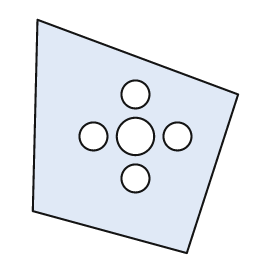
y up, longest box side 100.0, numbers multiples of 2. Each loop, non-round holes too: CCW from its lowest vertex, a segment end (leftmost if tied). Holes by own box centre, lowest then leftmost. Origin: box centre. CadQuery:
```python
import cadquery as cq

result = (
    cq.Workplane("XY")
    .moveTo(22.0, -50.0)
    .lineTo(44.0, 18.0)
    .lineTo(-42.0, 50.0)
    .lineTo(-44.0, -32.0)
    .close()
    .moveTo(0.0, -18.0)
    .circle(6.0)
    .moveTo(-18.0, 0.0)
    .circle(6.0)
    .moveTo(0.0, 0.0)
    .circle(8.0)
    .moveTo(18.0, 0.0)
    .circle(6.0)
    .moveTo(0.0, 18.0)
    .circle(6.0)
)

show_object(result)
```